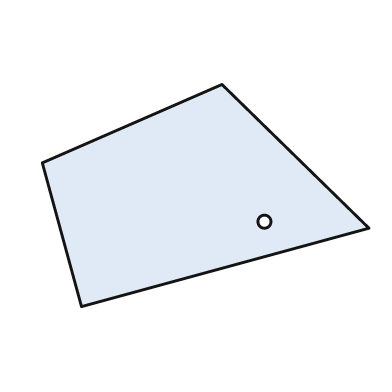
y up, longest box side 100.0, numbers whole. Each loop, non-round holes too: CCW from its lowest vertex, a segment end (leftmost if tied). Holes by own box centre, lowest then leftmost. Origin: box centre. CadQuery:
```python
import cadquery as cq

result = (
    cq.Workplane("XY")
    .moveTo(-38.0, -34.0)
    .lineTo(50.0, -10.0)
    .lineTo(5.0, 34.0)
    .lineTo(-50.0, 10.0)
    .close()
    .moveTo(18.0, -8.0)
    .circle(2.0)
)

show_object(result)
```